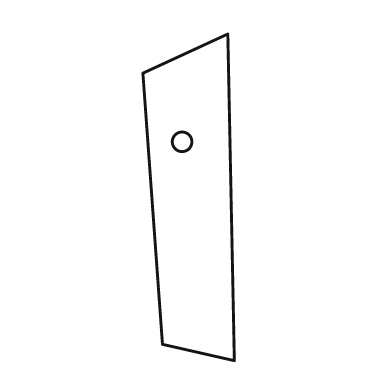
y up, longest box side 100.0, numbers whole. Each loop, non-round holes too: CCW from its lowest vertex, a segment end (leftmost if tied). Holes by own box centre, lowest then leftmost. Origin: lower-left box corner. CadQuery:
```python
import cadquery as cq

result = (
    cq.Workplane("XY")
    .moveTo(28.0, 0.0)
    .lineTo(26.0, 100.0)
    .lineTo(0.0, 88.0)
    .lineTo(6.0, 5.0)
    .close()
    .moveTo(12.0, 67.0)
    .circle(3.0)
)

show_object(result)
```